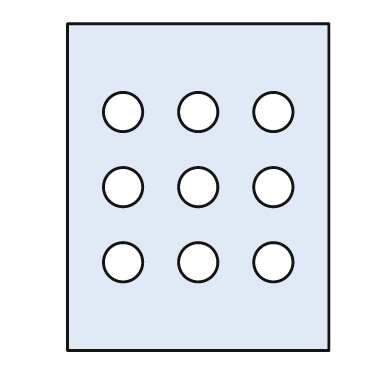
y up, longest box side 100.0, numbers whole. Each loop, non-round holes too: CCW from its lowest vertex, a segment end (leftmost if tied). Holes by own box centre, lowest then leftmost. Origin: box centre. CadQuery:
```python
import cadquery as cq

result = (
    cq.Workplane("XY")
    .moveTo(-40.0, -50.0)
    .lineTo(40.0, -50.0)
    .lineTo(40.0, 50.0)
    .lineTo(-40.0, 50.0)
    .close()
    .moveTo(-23.0, -23.0)
    .circle(6.0)
    .moveTo(0.0, -23.0)
    .circle(6.0)
    .moveTo(23.0, -23.0)
    .circle(6.0)
    .moveTo(-23.0, 0.0)
    .circle(6.0)
    .moveTo(0.0, 0.0)
    .circle(6.0)
    .moveTo(23.0, 0.0)
    .circle(6.0)
    .moveTo(-23.0, 23.0)
    .circle(6.0)
    .moveTo(0.0, 23.0)
    .circle(6.0)
    .moveTo(23.0, 23.0)
    .circle(6.0)
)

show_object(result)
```